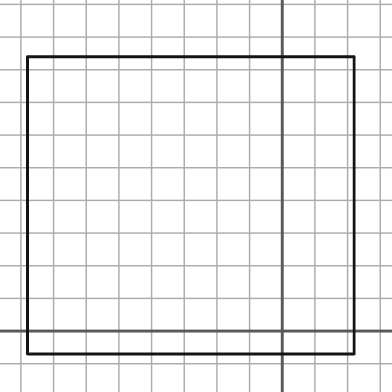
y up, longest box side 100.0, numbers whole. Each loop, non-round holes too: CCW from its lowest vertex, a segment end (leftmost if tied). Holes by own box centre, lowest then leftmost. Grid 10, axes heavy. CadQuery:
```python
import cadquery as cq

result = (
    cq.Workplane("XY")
    .moveTo(-78.0, -7.0)
    .lineTo(22.0, -7.0)
    .lineTo(22.0, 84.0)
    .lineTo(-78.0, 84.0)
    .close()
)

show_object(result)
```